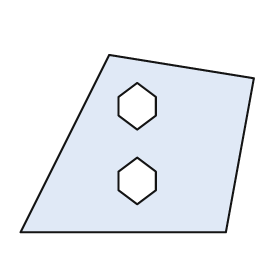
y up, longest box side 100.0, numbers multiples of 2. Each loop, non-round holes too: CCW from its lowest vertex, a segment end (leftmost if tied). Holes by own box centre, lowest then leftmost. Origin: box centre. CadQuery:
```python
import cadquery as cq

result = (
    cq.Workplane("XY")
    .moveTo(-50.0, -38.0)
    .lineTo(38.0, -38.0)
    .lineTo(50.0, 28.0)
    .lineTo(-12.0, 38.0)
    .close()
    .moveTo(0.0, -26.0)
    .lineTo(8.0, -20.0)
    .lineTo(8.0, -12.0)
    .lineTo(0.0, -6.0)
    .lineTo(-8.0, -12.0)
    .lineTo(-8.0, -20.0)
    .close()
    .moveTo(0.0, 6.0)
    .lineTo(8.0, 12.0)
    .lineTo(8.0, 20.0)
    .lineTo(0.0, 26.0)
    .lineTo(-8.0, 20.0)
    .lineTo(-8.0, 12.0)
    .close()
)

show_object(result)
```